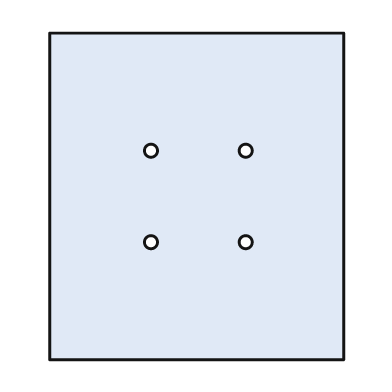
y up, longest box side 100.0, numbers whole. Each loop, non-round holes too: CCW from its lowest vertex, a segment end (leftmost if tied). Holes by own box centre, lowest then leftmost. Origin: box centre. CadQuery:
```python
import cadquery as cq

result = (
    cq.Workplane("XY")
    .moveTo(-45.0, -50.0)
    .lineTo(45.0, -50.0)
    .lineTo(45.0, 50.0)
    .lineTo(-45.0, 50.0)
    .close()
    .moveTo(-14.0, -14.0)
    .circle(2.0)
    .moveTo(15.0, -14.0)
    .circle(2.0)
    .moveTo(-14.0, 14.0)
    .circle(2.0)
    .moveTo(15.0, 14.0)
    .circle(2.0)
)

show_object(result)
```